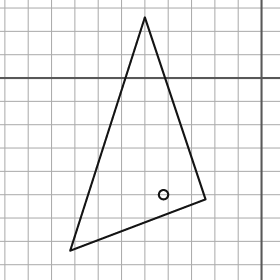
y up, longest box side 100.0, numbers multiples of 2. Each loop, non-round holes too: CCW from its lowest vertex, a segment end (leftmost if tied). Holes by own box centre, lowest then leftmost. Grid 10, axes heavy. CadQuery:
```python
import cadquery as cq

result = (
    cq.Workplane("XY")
    .moveTo(-82.0, -74.0)
    .lineTo(-24.0, -52.0)
    .lineTo(-50.0, 26.0)
    .close()
    .moveTo(-42.0, -50.0)
    .circle(2.0)
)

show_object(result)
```